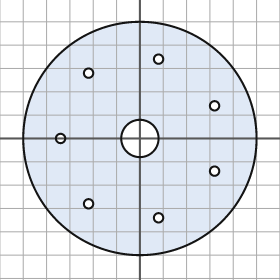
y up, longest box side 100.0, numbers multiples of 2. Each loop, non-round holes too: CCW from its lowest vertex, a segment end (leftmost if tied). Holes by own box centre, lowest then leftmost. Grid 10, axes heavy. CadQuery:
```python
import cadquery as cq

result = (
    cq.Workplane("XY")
    .moveTo(0.0, 0.0)
    .circle(50.0)
    .moveTo(8.0, -34.0)
    .circle(2.0)
    .moveTo(-22.0, -28.0)
    .circle(2.0)
    .moveTo(32.0, -14.0)
    .circle(2.0)
    .moveTo(-34.0, 0.0)
    .circle(2.0)
    .moveTo(0.0, 0.0)
    .circle(8.0)
    .moveTo(32.0, 14.0)
    .circle(2.0)
    .moveTo(-22.0, 28.0)
    .circle(2.0)
    .moveTo(8.0, 34.0)
    .circle(2.0)
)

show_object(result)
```